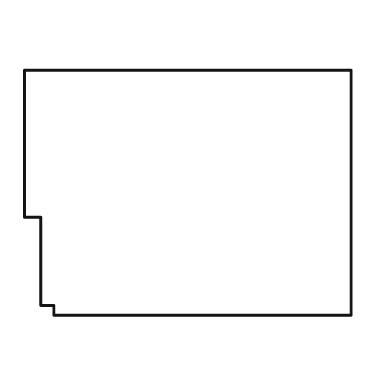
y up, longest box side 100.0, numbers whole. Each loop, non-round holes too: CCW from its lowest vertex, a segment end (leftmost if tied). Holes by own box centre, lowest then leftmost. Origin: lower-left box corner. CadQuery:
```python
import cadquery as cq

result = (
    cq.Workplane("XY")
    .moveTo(9.0, 0.0)
    .lineTo(100.0, 0.0)
    .lineTo(100.0, 75.0)
    .lineTo(0.0, 75.0)
    .lineTo(0.0, 30.0)
    .lineTo(5.0, 30.0)
    .lineTo(5.0, 3.0)
    .lineTo(9.0, 3.0)
    .close()
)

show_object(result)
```